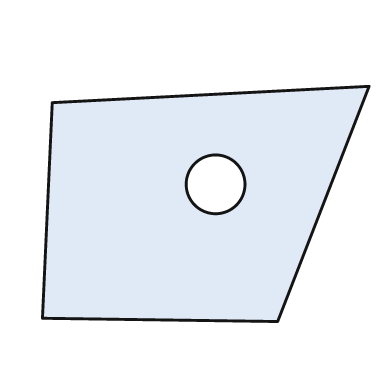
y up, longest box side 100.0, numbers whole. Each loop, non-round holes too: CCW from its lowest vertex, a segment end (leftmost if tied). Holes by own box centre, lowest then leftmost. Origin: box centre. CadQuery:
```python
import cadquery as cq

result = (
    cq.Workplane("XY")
    .moveTo(22.0, -36.0)
    .lineTo(50.0, 36.0)
    .lineTo(-47.0, 31.0)
    .lineTo(-50.0, -35.0)
    .close()
    .moveTo(3.0, 6.0)
    .circle(9.0)
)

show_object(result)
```